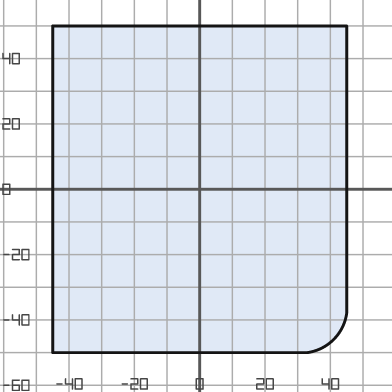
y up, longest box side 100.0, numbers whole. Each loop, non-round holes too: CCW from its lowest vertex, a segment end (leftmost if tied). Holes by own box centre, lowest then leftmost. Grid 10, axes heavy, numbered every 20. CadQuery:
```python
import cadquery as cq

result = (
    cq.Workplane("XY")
    .moveTo(-45.0, -50.0)
    .lineTo(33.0, -50.0)
    .threePointArc((41.0, -46.0), (45.0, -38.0))
    .lineTo(45.0, 50.0)
    .lineTo(-45.0, 50.0)
    .close()
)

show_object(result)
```